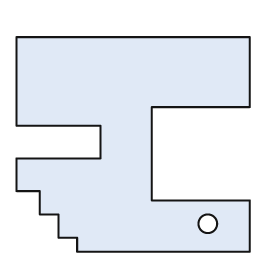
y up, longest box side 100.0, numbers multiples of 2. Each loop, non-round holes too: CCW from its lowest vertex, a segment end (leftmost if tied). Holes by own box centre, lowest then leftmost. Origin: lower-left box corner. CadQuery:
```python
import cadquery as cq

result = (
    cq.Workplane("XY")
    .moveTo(26.0, 0.0)
    .lineTo(100.0, 0.0)
    .lineTo(100.0, 22.0)
    .lineTo(58.0, 22.0)
    .lineTo(58.0, 62.0)
    .lineTo(100.0, 62.0)
    .lineTo(100.0, 92.0)
    .lineTo(0.0, 92.0)
    .lineTo(0.0, 54.0)
    .lineTo(36.0, 54.0)
    .lineTo(36.0, 40.0)
    .lineTo(0.0, 40.0)
    .lineTo(0.0, 26.0)
    .lineTo(10.0, 26.0)
    .lineTo(10.0, 16.0)
    .lineTo(18.0, 16.0)
    .lineTo(18.0, 6.0)
    .lineTo(26.0, 6.0)
    .close()
    .moveTo(82.0, 12.0)
    .circle(4.0)
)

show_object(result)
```